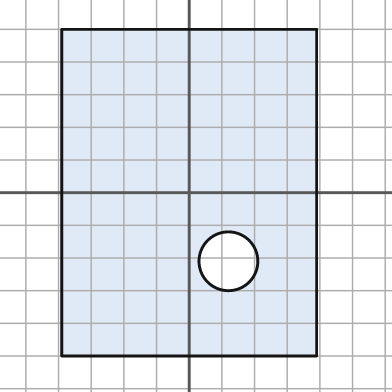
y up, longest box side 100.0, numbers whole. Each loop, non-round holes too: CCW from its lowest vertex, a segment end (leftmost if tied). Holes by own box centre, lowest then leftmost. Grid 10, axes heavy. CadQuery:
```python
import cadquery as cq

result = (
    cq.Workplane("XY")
    .moveTo(-39.0, -50.0)
    .lineTo(39.0, -50.0)
    .lineTo(39.0, 50.0)
    .lineTo(-39.0, 50.0)
    .close()
    .moveTo(12.0, -21.0)
    .circle(9.0)
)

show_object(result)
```